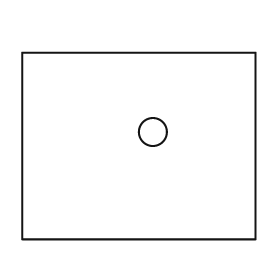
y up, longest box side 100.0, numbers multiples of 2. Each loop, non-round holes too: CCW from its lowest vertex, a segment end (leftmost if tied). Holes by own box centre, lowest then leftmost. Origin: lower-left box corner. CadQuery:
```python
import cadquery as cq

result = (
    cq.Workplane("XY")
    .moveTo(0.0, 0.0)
    .lineTo(100.0, 0.0)
    .lineTo(100.0, 80.0)
    .lineTo(0.0, 80.0)
    .close()
    .moveTo(56.0, 46.0)
    .circle(6.0)
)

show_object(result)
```